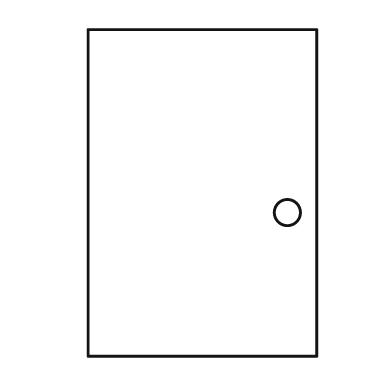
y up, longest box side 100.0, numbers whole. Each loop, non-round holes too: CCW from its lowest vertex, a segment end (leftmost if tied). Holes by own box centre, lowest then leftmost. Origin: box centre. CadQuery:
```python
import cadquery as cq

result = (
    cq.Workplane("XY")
    .moveTo(-35.0, -50.0)
    .lineTo(35.0, -50.0)
    .lineTo(35.0, 50.0)
    .lineTo(-35.0, 50.0)
    .close()
    .moveTo(26.0, -6.0)
    .circle(4.0)
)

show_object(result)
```